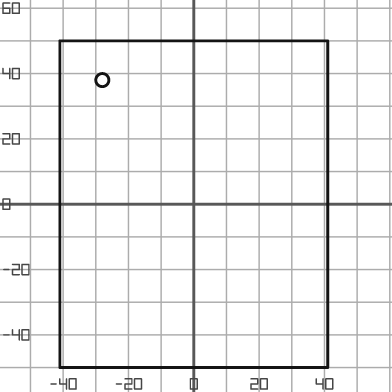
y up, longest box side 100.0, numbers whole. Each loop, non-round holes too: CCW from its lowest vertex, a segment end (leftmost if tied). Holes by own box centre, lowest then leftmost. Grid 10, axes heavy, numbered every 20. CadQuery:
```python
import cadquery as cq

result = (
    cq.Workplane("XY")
    .moveTo(-41.0, -50.0)
    .lineTo(41.0, -50.0)
    .lineTo(41.0, 50.0)
    .lineTo(-41.0, 50.0)
    .close()
    .moveTo(-28.0, 38.0)
    .circle(2.0)
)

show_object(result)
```